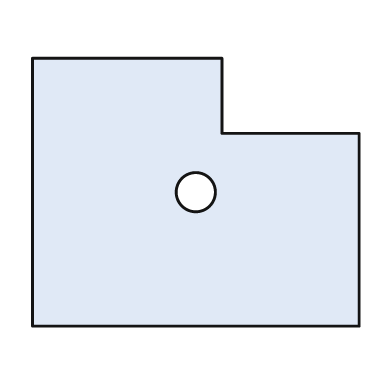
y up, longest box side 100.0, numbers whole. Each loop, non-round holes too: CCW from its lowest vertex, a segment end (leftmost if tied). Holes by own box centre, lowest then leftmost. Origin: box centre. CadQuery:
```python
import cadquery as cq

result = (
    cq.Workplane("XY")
    .moveTo(-50.0, -41.0)
    .lineTo(50.0, -41.0)
    .lineTo(50.0, 18.0)
    .lineTo(8.0, 18.0)
    .lineTo(8.0, 41.0)
    .lineTo(-50.0, 41.0)
    .close()
    .moveTo(0.0, 0.0)
    .circle(6.0)
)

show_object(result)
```